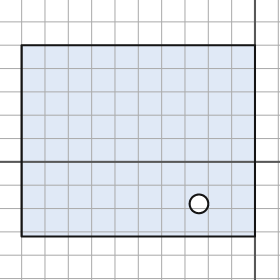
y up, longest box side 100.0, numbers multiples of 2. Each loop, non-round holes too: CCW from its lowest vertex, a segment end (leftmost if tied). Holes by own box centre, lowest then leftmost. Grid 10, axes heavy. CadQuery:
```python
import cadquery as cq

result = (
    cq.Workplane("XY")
    .moveTo(-100.0, -32.0)
    .lineTo(0.0, -32.0)
    .lineTo(0.0, 50.0)
    .lineTo(-100.0, 50.0)
    .close()
    .moveTo(-24.0, -18.0)
    .circle(4.0)
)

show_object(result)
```